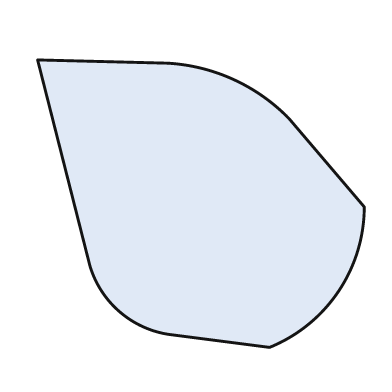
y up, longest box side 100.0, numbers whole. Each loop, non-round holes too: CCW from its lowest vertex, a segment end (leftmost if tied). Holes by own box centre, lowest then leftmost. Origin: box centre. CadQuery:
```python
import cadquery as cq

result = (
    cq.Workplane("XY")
    .moveTo(21.0, -44.0)
    .threePointArc((42.0, -27.0), (50.0, -1.0))
    .lineTo(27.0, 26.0)
    .threePointArc((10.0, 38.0), (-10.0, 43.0))
    .lineTo(-50.0, 44.0)
    .lineTo(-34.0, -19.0)
    .threePointArc((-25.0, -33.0), (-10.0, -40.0))
    .close()
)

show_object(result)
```